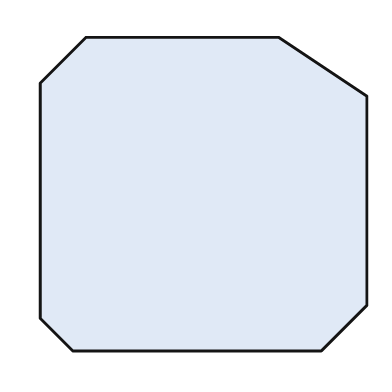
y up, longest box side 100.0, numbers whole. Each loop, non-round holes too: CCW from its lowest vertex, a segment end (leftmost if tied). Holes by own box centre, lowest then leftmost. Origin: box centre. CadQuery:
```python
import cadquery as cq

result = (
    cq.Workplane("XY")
    .moveTo(-40.0, -48.0)
    .lineTo(36.0, -48.0)
    .lineTo(50.0, -34.0)
    .lineTo(50.0, 30.0)
    .lineTo(23.0, 48.0)
    .lineTo(-36.0, 48.0)
    .lineTo(-50.0, 34.0)
    .lineTo(-50.0, -38.0)
    .close()
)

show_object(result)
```